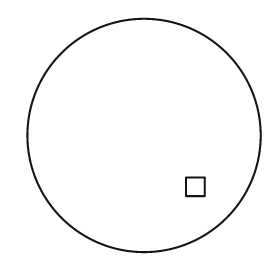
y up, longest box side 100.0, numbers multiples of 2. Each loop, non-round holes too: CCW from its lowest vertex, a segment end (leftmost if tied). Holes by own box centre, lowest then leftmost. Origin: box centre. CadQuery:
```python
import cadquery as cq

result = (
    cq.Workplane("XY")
    .moveTo(0.0, 0.0)
    .circle(50.0)
    .moveTo(18.0, -26.0)
    .lineTo(26.0, -26.0)
    .lineTo(26.0, -18.0)
    .lineTo(18.0, -18.0)
    .close()
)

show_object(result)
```